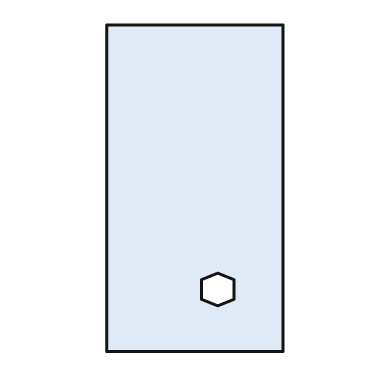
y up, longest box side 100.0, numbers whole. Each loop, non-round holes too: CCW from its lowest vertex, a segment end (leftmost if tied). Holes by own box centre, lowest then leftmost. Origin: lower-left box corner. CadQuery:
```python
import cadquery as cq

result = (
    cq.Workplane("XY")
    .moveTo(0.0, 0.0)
    .lineTo(54.0, 0.0)
    .lineTo(54.0, 100.0)
    .lineTo(0.0, 100.0)
    .close()
    .moveTo(34.0, 14.0)
    .lineTo(39.0, 16.0)
    .lineTo(39.0, 22.0)
    .lineTo(34.0, 24.0)
    .lineTo(29.0, 22.0)
    .lineTo(29.0, 16.0)
    .close()
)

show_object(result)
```